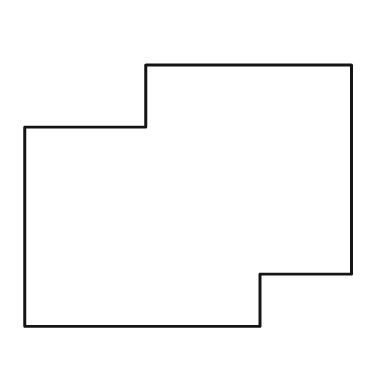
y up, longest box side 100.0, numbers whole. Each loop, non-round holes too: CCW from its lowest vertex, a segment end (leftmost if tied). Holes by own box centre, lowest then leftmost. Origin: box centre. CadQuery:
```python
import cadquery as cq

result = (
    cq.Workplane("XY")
    .moveTo(-50.0, -40.0)
    .lineTo(22.0, -40.0)
    .lineTo(22.0, -24.0)
    .lineTo(50.0, -24.0)
    .lineTo(50.0, 40.0)
    .lineTo(-13.0, 40.0)
    .lineTo(-13.0, 21.0)
    .lineTo(-50.0, 21.0)
    .close()
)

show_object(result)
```